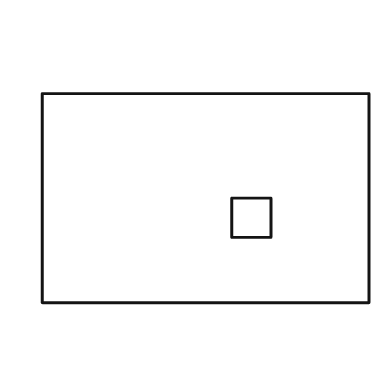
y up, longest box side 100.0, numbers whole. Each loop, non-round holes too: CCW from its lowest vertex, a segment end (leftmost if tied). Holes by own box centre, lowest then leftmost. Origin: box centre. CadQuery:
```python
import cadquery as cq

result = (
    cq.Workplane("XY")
    .moveTo(-50.0, -32.0)
    .lineTo(50.0, -32.0)
    .lineTo(50.0, 32.0)
    .lineTo(-50.0, 32.0)
    .close()
    .moveTo(8.0, -12.0)
    .lineTo(20.0, -12.0)
    .lineTo(20.0, 0.0)
    .lineTo(8.0, 0.0)
    .close()
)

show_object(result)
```